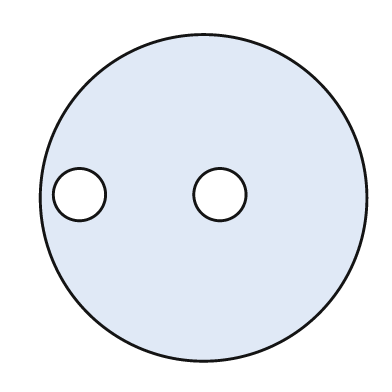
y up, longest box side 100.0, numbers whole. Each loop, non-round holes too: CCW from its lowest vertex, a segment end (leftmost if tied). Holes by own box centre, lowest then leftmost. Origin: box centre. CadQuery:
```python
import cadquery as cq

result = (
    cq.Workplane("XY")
    .moveTo(0.0, 0.0)
    .circle(50.0)
    .moveTo(-38.0, 1.0)
    .circle(8.0)
    .moveTo(5.0, 1.0)
    .circle(8.0)
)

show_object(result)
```